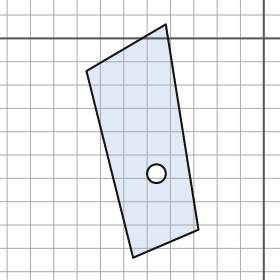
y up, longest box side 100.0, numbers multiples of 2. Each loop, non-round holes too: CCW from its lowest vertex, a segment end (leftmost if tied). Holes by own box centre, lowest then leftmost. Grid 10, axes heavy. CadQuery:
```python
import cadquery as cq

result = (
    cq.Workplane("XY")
    .moveTo(-56.0, -94.0)
    .lineTo(-28.0, -82.0)
    .lineTo(-42.0, 6.0)
    .lineTo(-76.0, -14.0)
    .close()
    .moveTo(-46.0, -58.0)
    .circle(4.0)
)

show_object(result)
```